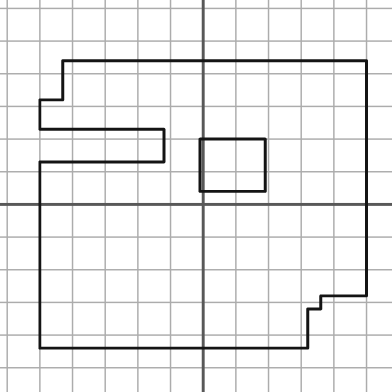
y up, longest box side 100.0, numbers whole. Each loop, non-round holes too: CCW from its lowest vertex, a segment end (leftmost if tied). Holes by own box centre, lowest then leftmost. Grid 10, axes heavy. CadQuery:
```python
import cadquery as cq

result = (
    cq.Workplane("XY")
    .moveTo(-50.0, -44.0)
    .lineTo(32.0, -44.0)
    .lineTo(32.0, -32.0)
    .lineTo(36.0, -32.0)
    .lineTo(36.0, -28.0)
    .lineTo(50.0, -28.0)
    .lineTo(50.0, 44.0)
    .lineTo(-43.0, 44.0)
    .lineTo(-43.0, 32.0)
    .lineTo(-50.0, 32.0)
    .lineTo(-50.0, 23.0)
    .lineTo(-12.0, 23.0)
    .lineTo(-12.0, 13.0)
    .lineTo(-50.0, 13.0)
    .close()
    .moveTo(-1.0, 4.0)
    .lineTo(19.0, 4.0)
    .lineTo(19.0, 20.0)
    .lineTo(-1.0, 20.0)
    .close()
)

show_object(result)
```